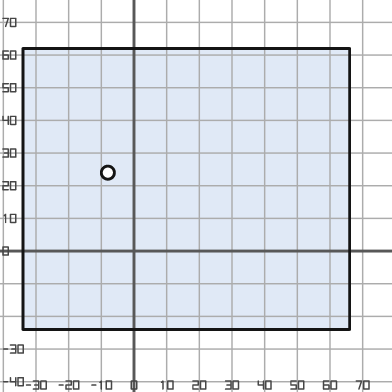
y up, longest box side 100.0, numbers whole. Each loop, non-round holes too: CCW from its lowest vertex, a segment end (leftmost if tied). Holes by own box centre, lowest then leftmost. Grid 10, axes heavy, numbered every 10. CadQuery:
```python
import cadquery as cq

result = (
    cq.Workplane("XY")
    .moveTo(-34.0, -24.0)
    .lineTo(66.0, -24.0)
    .lineTo(66.0, 62.0)
    .lineTo(-34.0, 62.0)
    .close()
    .moveTo(-8.0, 24.0)
    .circle(2.0)
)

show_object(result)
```